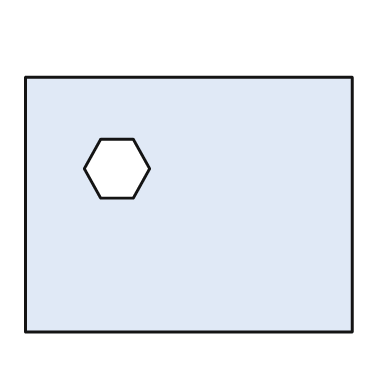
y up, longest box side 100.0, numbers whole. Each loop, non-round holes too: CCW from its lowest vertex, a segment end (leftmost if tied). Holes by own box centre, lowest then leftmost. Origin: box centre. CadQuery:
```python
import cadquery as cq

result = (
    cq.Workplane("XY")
    .moveTo(-50.0, -39.0)
    .lineTo(50.0, -39.0)
    .lineTo(50.0, 39.0)
    .lineTo(-50.0, 39.0)
    .close()
    .moveTo(-27.0, 2.0)
    .lineTo(-17.0, 2.0)
    .lineTo(-12.0, 11.0)
    .lineTo(-17.0, 20.0)
    .lineTo(-27.0, 20.0)
    .lineTo(-32.0, 11.0)
    .close()
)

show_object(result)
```